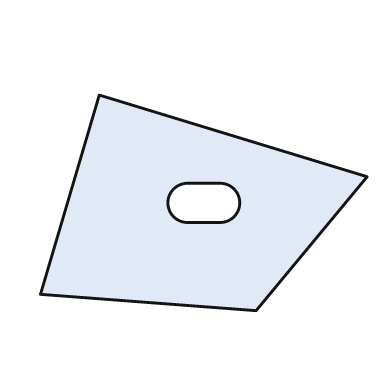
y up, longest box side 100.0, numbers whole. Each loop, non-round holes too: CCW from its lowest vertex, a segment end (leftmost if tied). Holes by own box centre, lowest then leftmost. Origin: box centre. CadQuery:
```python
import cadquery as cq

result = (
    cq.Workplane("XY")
    .moveTo(16.0, -33.0)
    .lineTo(50.0, 8.0)
    .lineTo(-32.0, 33.0)
    .lineTo(-50.0, -28.0)
    .close()
    .moveTo(-5.0, -6.0)
    .lineTo(5.0, -6.0)
    .threePointArc((11.0, 0.0), (5.0, 6.0))
    .lineTo(-5.0, 6.0)
    .threePointArc((-11.0, 0.0), (-5.0, -6.0))
    .close()
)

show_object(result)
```